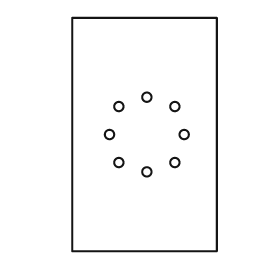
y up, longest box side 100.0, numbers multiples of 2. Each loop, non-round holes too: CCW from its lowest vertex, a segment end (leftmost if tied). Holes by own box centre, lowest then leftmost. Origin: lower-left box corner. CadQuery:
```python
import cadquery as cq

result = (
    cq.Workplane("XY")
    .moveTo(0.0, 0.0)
    .lineTo(62.0, 0.0)
    .lineTo(62.0, 100.0)
    .lineTo(0.0, 100.0)
    .close()
    .moveTo(32.0, 34.0)
    .circle(2.0)
    .moveTo(20.0, 38.0)
    .circle(2.0)
    .moveTo(44.0, 38.0)
    .circle(2.0)
    .moveTo(16.0, 50.0)
    .circle(2.0)
    .moveTo(48.0, 50.0)
    .circle(2.0)
    .moveTo(20.0, 62.0)
    .circle(2.0)
    .moveTo(44.0, 62.0)
    .circle(2.0)
    .moveTo(32.0, 66.0)
    .circle(2.0)
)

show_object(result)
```